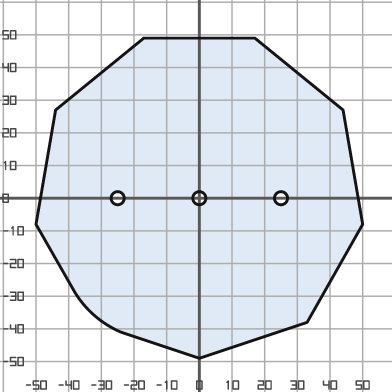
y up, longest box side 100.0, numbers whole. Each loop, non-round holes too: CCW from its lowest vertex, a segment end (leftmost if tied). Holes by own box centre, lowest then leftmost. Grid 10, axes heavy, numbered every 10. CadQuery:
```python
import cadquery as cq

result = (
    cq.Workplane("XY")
    .moveTo(0.0, -49.0)
    .lineTo(33.0, -38.0)
    .lineTo(50.0, -8.0)
    .lineTo(44.0, 27.0)
    .lineTo(17.0, 49.0)
    .lineTo(-17.0, 49.0)
    .lineTo(-44.0, 27.0)
    .lineTo(-50.0, -8.0)
    .lineTo(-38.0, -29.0)
    .threePointArc((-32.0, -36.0), (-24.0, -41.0))
    .close()
    .moveTo(-25.0, 0.0)
    .circle(2.0)
    .moveTo(0.0, 0.0)
    .circle(2.0)
    .moveTo(25.0, 0.0)
    .circle(2.0)
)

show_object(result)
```